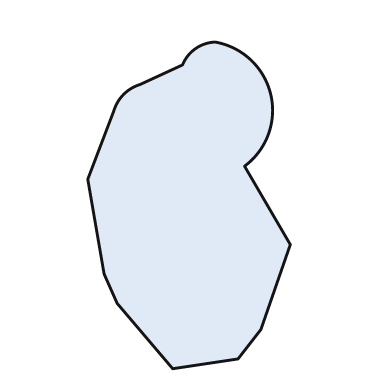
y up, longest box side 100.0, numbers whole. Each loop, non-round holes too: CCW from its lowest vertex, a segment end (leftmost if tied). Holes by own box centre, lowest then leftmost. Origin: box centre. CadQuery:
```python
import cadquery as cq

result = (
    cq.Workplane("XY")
    .moveTo(-5.0, -50.0)
    .lineTo(15.0, -47.0)
    .lineTo(22.0, -38.0)
    .lineTo(31.0, -12.0)
    .lineTo(17.0, 12.0)
    .threePointArc((25.0, 34.0), (8.0, 50.0))
    .threePointArc((2.0, 48.0), (-2.0, 43.0))
    .lineTo(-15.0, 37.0)
    .threePointArc((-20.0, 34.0), (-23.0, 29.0))
    .lineTo(-31.0, 8.0)
    .lineTo(-26.0, -21.0)
    .lineTo(-22.0, -30.0)
    .close()
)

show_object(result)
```